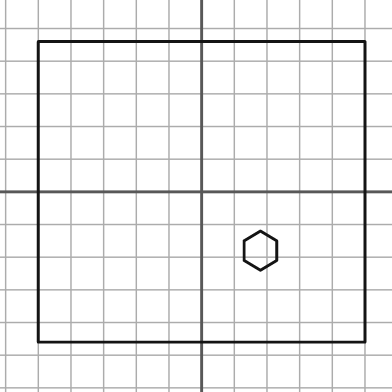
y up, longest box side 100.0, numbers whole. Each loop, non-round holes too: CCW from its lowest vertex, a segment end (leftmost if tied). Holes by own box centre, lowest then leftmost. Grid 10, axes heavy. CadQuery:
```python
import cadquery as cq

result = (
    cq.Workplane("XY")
    .moveTo(-50.0, -46.0)
    .lineTo(50.0, -46.0)
    .lineTo(50.0, 46.0)
    .lineTo(-50.0, 46.0)
    .close()
    .moveTo(18.0, -24.0)
    .lineTo(23.0, -21.0)
    .lineTo(23.0, -15.0)
    .lineTo(18.0, -12.0)
    .lineTo(13.0, -15.0)
    .lineTo(13.0, -21.0)
    .close()
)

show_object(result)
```